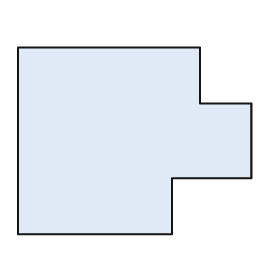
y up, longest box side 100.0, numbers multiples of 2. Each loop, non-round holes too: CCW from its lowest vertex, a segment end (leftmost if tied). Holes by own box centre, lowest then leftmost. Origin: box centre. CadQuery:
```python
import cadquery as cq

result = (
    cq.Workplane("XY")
    .moveTo(-50.0, -40.0)
    .lineTo(16.0, -40.0)
    .lineTo(16.0, -16.0)
    .lineTo(50.0, -16.0)
    .lineTo(50.0, 16.0)
    .lineTo(28.0, 16.0)
    .lineTo(28.0, 40.0)
    .lineTo(-50.0, 40.0)
    .close()
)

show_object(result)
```